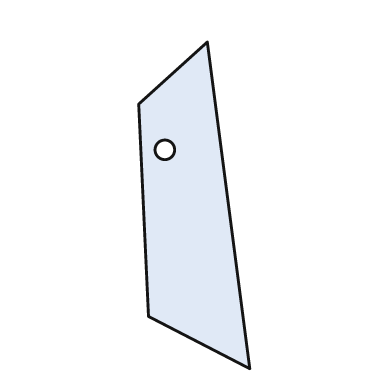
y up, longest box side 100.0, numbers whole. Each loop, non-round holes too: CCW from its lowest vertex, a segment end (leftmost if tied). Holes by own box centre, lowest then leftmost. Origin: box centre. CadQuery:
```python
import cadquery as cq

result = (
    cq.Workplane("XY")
    .moveTo(17.0, -50.0)
    .lineTo(4.0, 50.0)
    .lineTo(-17.0, 31.0)
    .lineTo(-14.0, -34.0)
    .close()
    .moveTo(-9.0, 17.0)
    .circle(3.0)
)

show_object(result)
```